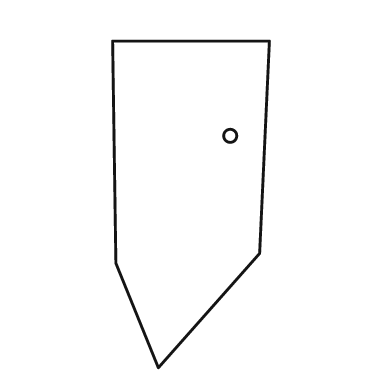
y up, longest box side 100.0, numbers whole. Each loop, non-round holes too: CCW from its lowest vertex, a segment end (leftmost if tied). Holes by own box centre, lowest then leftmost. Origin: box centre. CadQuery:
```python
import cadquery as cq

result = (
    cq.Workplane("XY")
    .moveTo(-10.0, -50.0)
    .lineTo(21.0, -15.0)
    .lineTo(24.0, 50.0)
    .lineTo(-24.0, 50.0)
    .lineTo(-23.0, -18.0)
    .close()
    .moveTo(12.0, 21.0)
    .circle(2.0)
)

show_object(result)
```